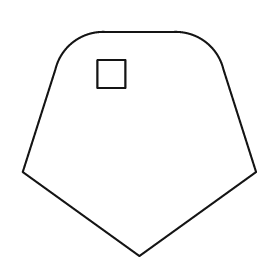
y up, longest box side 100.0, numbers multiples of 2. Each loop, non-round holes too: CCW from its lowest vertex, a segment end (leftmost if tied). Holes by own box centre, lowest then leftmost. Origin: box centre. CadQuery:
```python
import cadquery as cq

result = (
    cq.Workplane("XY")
    .moveTo(0.0, -48.0)
    .lineTo(50.0, -12.0)
    .lineTo(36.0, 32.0)
    .threePointArc((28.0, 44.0), (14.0, 48.0))
    .lineTo(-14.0, 48.0)
    .threePointArc((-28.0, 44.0), (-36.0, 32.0))
    .lineTo(-50.0, -12.0)
    .close()
    .moveTo(-18.0, 24.0)
    .lineTo(-6.0, 24.0)
    .lineTo(-6.0, 36.0)
    .lineTo(-18.0, 36.0)
    .close()
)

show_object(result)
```